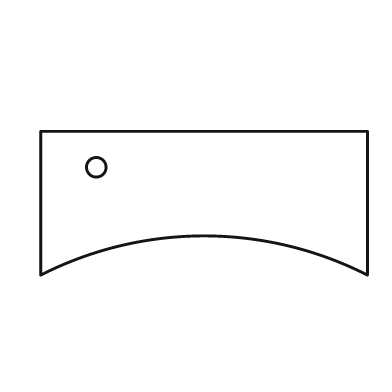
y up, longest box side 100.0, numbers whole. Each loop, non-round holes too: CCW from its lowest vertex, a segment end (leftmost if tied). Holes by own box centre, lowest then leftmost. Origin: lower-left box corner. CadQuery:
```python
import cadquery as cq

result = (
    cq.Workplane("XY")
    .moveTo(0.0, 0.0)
    .threePointArc((50.0, 12.0), (100.0, 0.0))
    .lineTo(100.0, 44.0)
    .lineTo(0.0, 44.0)
    .close()
    .moveTo(17.0, 33.0)
    .circle(3.0)
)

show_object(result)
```